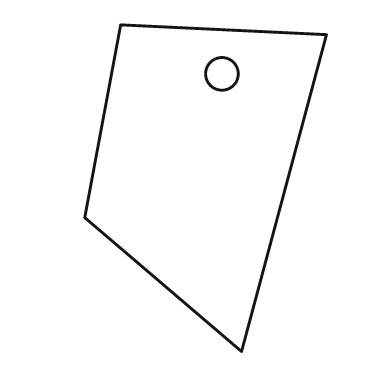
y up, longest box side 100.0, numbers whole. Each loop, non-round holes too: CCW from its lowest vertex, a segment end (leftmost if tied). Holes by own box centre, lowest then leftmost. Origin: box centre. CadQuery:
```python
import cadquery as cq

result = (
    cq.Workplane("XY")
    .moveTo(11.0, -50.0)
    .lineTo(37.0, 47.0)
    .lineTo(-26.0, 50.0)
    .lineTo(-37.0, -9.0)
    .close()
    .moveTo(5.0, 35.0)
    .circle(5.0)
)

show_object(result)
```